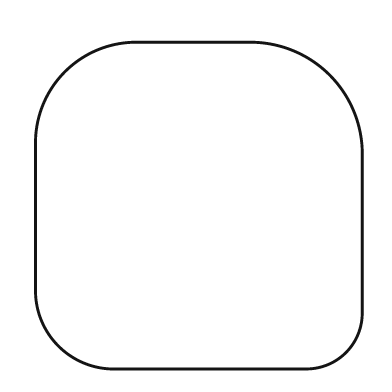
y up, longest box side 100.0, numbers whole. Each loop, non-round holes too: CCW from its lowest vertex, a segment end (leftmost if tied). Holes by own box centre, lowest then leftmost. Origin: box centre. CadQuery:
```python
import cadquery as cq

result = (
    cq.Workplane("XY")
    .moveTo(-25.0, -50.0)
    .lineTo(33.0, -50.0)
    .threePointArc((45.0, -45.0), (50.0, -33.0))
    .lineTo(50.0, 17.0)
    .threePointArc((40.0, 40.0), (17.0, 50.0))
    .lineTo(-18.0, 50.0)
    .threePointArc((-41.0, 41.0), (-50.0, 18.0))
    .lineTo(-50.0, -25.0)
    .threePointArc((-43.0, -43.0), (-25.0, -50.0))
    .close()
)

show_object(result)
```